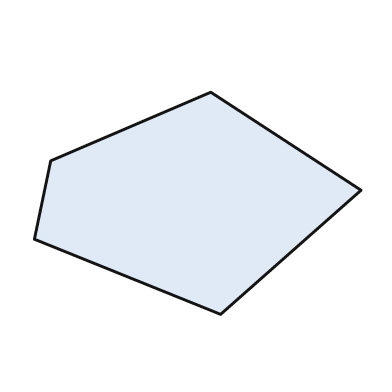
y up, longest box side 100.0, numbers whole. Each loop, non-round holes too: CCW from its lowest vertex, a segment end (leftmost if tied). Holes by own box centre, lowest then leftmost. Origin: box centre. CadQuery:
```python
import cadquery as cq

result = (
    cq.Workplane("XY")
    .moveTo(7.0, -34.0)
    .lineTo(50.0, 4.0)
    .lineTo(4.0, 34.0)
    .lineTo(-45.0, 13.0)
    .lineTo(-50.0, -11.0)
    .close()
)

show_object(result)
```